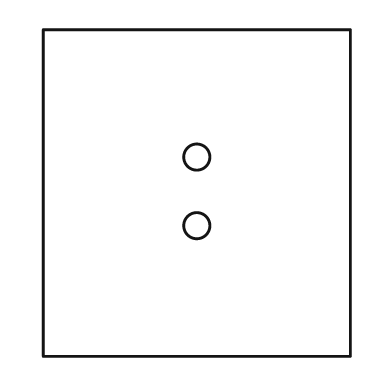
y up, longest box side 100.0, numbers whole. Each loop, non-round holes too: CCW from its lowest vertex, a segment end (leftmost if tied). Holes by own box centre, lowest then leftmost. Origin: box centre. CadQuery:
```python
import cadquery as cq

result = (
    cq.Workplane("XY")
    .moveTo(-47.0, -50.0)
    .lineTo(47.0, -50.0)
    .lineTo(47.0, 50.0)
    .lineTo(-47.0, 50.0)
    .close()
    .moveTo(0.0, -10.0)
    .circle(4.0)
    .moveTo(0.0, 11.0)
    .circle(4.0)
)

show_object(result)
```